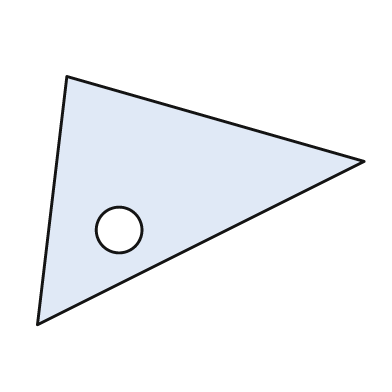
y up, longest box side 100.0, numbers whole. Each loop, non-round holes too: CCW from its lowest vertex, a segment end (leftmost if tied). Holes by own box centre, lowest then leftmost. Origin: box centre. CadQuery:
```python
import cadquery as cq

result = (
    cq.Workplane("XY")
    .moveTo(-50.0, -38.0)
    .lineTo(50.0, 12.0)
    .lineTo(-41.0, 38.0)
    .close()
    .moveTo(-25.0, -9.0)
    .circle(7.0)
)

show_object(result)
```